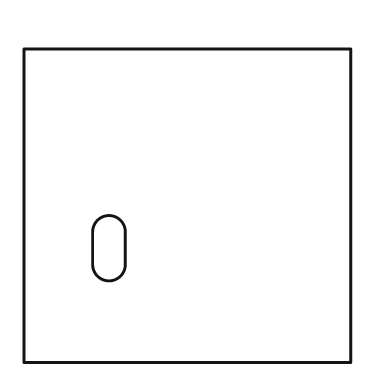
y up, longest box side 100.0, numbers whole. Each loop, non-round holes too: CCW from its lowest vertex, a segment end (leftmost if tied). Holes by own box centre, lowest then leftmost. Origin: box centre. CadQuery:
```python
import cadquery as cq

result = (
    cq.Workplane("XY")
    .moveTo(-50.0, -48.0)
    .lineTo(50.0, -48.0)
    .lineTo(50.0, 48.0)
    .lineTo(-50.0, 48.0)
    .close()
    .moveTo(-29.0, -18.0)
    .threePointArc((-24.0, -23.0), (-19.0, -18.0))
    .lineTo(-19.0, -8.0)
    .threePointArc((-24.0, -3.0), (-29.0, -8.0))
    .close()
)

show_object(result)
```